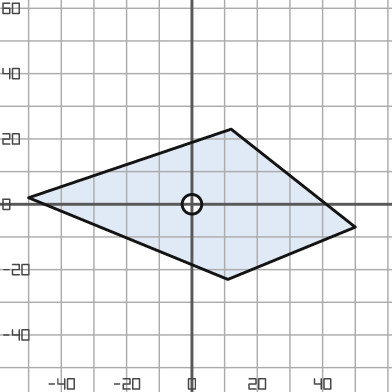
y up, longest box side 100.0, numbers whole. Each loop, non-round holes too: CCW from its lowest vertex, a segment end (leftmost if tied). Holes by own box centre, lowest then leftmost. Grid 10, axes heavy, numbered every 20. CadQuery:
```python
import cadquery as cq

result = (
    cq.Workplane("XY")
    .moveTo(11.0, -23.0)
    .lineTo(50.0, -7.0)
    .lineTo(12.0, 23.0)
    .lineTo(-50.0, 2.0)
    .close()
    .moveTo(0.0, 0.0)
    .circle(3.0)
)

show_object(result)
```